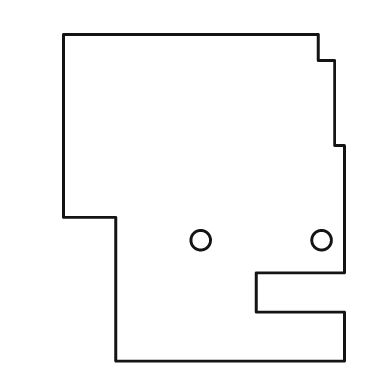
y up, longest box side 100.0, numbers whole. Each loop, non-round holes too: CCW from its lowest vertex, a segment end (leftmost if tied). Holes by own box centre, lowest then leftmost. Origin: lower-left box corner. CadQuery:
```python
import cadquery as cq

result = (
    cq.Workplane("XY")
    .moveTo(16.0, 0.0)
    .lineTo(86.0, 0.0)
    .lineTo(86.0, 15.0)
    .lineTo(59.0, 15.0)
    .lineTo(59.0, 27.0)
    .lineTo(86.0, 27.0)
    .lineTo(86.0, 66.0)
    .lineTo(83.0, 66.0)
    .lineTo(83.0, 92.0)
    .lineTo(78.0, 92.0)
    .lineTo(78.0, 100.0)
    .lineTo(0.0, 100.0)
    .lineTo(0.0, 44.0)
    .lineTo(16.0, 44.0)
    .close()
    .moveTo(42.0, 37.0)
    .circle(3.0)
    .moveTo(79.0, 37.0)
    .circle(3.0)
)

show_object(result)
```